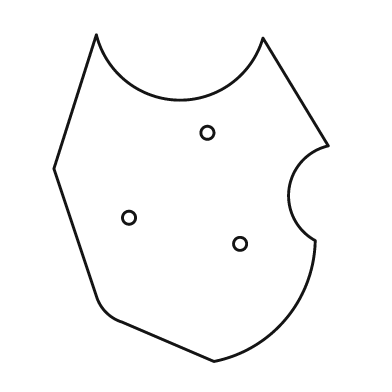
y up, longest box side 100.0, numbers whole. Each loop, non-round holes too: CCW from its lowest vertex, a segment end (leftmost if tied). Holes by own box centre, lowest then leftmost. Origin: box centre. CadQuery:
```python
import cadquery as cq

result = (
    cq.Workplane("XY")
    .moveTo(7.0, -50.0)
    .threePointArc((29.0, -37.0), (38.0, -13.0))
    .threePointArc((30.0, 3.0), (42.0, 16.0))
    .lineTo(22.0, 49.0)
    .threePointArc((-4.0, 30.0), (-29.0, 50.0))
    .lineTo(-42.0, 9.0)
    .lineTo(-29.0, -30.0)
    .threePointArc((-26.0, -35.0), (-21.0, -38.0))
    .close()
    .moveTo(15.0, -14.0)
    .circle(2.0)
    .moveTo(-19.0, -6.0)
    .circle(2.0)
    .moveTo(5.0, 20.0)
    .circle(2.0)
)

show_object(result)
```